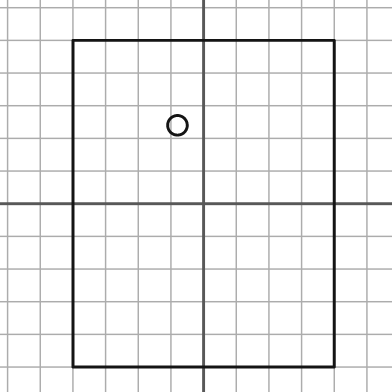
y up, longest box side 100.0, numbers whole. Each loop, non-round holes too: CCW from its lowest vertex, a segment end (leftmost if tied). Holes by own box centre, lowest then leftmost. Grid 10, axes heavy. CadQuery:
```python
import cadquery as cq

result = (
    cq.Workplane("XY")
    .moveTo(-40.0, -50.0)
    .lineTo(40.0, -50.0)
    .lineTo(40.0, 50.0)
    .lineTo(-40.0, 50.0)
    .close()
    .moveTo(-8.0, 24.0)
    .circle(3.0)
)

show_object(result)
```